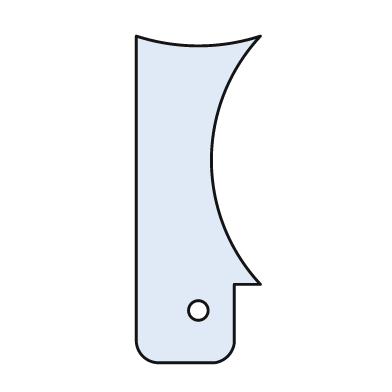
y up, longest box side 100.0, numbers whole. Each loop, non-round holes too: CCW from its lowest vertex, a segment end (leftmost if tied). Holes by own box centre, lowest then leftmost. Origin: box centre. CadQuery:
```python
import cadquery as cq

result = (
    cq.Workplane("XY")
    .moveTo(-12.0, -50.0)
    .lineTo(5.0, -50.0)
    .threePointArc((9.0, -48.0), (11.0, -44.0))
    .lineTo(11.0, -26.0)
    .lineTo(19.0, -26.0)
    .threePointArc((4.0, 12.0), (19.0, 50.0))
    .threePointArc((0.0, 47.0), (-19.0, 50.0))
    .lineTo(-19.0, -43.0)
    .threePointArc((-17.0, -48.0), (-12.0, -50.0))
    .close()
    .moveTo(0.0, -34.0)
    .circle(3.0)
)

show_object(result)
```